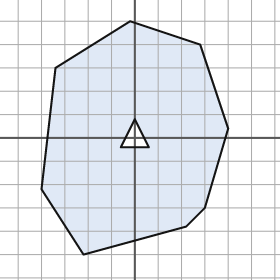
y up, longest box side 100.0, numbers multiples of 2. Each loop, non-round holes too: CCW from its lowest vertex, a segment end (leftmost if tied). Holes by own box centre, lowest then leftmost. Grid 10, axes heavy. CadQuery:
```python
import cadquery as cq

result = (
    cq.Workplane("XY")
    .moveTo(-22.0, -50.0)
    .lineTo(22.0, -38.0)
    .lineTo(30.0, -30.0)
    .lineTo(40.0, 4.0)
    .lineTo(28.0, 40.0)
    .lineTo(-2.0, 50.0)
    .lineTo(-34.0, 30.0)
    .lineTo(-40.0, -22.0)
    .close()
    .moveTo(-6.0, -4.0)
    .lineTo(6.0, -4.0)
    .lineTo(0.0, 8.0)
    .close()
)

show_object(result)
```